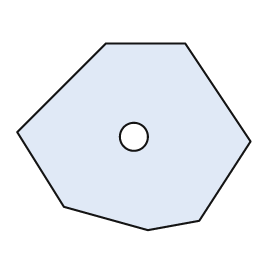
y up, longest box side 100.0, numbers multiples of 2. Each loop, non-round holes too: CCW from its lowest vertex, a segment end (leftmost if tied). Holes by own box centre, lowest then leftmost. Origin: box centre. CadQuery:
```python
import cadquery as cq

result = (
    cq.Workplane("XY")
    .moveTo(6.0, -40.0)
    .lineTo(28.0, -36.0)
    .lineTo(50.0, -2.0)
    .lineTo(22.0, 40.0)
    .lineTo(-12.0, 40.0)
    .lineTo(-50.0, 2.0)
    .lineTo(-30.0, -30.0)
    .close()
    .moveTo(0.0, 0.0)
    .circle(6.0)
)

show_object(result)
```